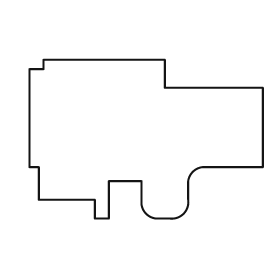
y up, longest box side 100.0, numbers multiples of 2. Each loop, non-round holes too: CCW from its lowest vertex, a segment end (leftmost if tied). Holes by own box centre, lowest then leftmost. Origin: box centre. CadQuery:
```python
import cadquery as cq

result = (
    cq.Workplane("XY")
    .moveTo(-22.0, -34.0)
    .lineTo(-16.0, -34.0)
    .lineTo(-16.0, -18.0)
    .lineTo(-2.0, -18.0)
    .lineTo(-2.0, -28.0)
    .threePointArc((0.0, -32.0), (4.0, -34.0))
    .lineTo(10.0, -34.0)
    .threePointArc((16.0, -32.0), (18.0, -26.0))
    .lineTo(18.0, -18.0)
    .threePointArc((20.0, -14.0), (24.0, -12.0))
    .lineTo(50.0, -12.0)
    .lineTo(50.0, 22.0)
    .lineTo(8.0, 22.0)
    .lineTo(8.0, 34.0)
    .lineTo(-44.0, 34.0)
    .lineTo(-44.0, 30.0)
    .lineTo(-50.0, 30.0)
    .lineTo(-50.0, -12.0)
    .lineTo(-46.0, -12.0)
    .lineTo(-46.0, -26.0)
    .lineTo(-22.0, -26.0)
    .close()
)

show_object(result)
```